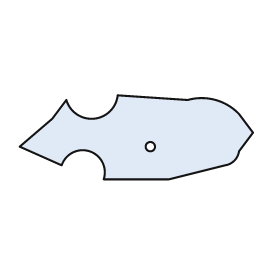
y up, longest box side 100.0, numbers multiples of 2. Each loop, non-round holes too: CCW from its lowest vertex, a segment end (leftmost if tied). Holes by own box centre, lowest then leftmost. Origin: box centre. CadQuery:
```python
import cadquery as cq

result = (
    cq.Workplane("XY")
    .moveTo(-14.0, -18.0)
    .lineTo(14.0, -18.0)
    .lineTo(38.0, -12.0)
    .threePointArc((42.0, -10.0), (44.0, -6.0))
    .lineTo(50.0, 2.0)
    .lineTo(44.0, 10.0)
    .threePointArc((34.0, 16.0), (22.0, 16.0))
    .lineTo(-8.0, 18.0)
    .threePointArc((-18.0, 8.0), (-30.0, 16.0))
    .lineTo(-36.0, 8.0)
    .lineTo(-50.0, -4.0)
    .lineTo(-32.0, -12.0)
    .threePointArc((-20.0, -6.0), (-14.0, -18.0))
    .close()
    .moveTo(6.0, -4.0)
    .circle(2.0)
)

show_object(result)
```